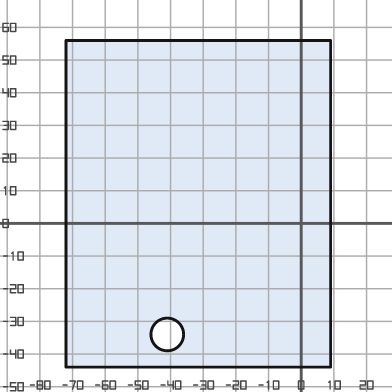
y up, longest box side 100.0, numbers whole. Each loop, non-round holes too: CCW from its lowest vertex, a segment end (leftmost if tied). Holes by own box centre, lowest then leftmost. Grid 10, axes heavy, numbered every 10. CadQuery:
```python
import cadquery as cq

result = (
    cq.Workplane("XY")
    .moveTo(-72.0, -44.0)
    .lineTo(9.0, -44.0)
    .lineTo(9.0, 56.0)
    .lineTo(-72.0, 56.0)
    .close()
    .moveTo(-41.0, -34.0)
    .circle(5.0)
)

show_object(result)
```